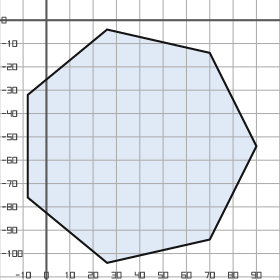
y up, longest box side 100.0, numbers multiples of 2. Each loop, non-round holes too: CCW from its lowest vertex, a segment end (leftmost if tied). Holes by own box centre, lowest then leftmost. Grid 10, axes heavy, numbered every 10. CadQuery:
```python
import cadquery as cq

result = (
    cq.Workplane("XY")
    .moveTo(26.0, -104.0)
    .lineTo(70.0, -94.0)
    .lineTo(90.0, -54.0)
    .lineTo(70.0, -14.0)
    .lineTo(26.0, -4.0)
    .lineTo(-8.0, -32.0)
    .lineTo(-8.0, -76.0)
    .close()
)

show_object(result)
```